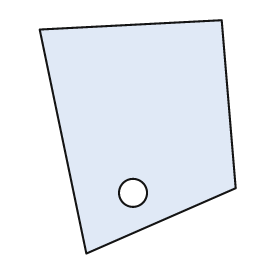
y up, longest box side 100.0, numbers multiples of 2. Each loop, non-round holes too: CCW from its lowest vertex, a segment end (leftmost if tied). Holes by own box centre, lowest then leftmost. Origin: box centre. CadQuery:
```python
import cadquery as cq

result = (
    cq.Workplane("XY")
    .moveTo(-22.0, -50.0)
    .lineTo(42.0, -22.0)
    .lineTo(36.0, 50.0)
    .lineTo(-42.0, 46.0)
    .close()
    .moveTo(-2.0, -24.0)
    .circle(6.0)
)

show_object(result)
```